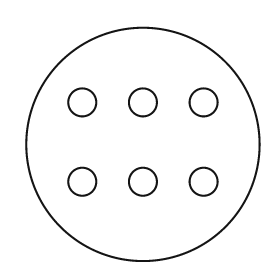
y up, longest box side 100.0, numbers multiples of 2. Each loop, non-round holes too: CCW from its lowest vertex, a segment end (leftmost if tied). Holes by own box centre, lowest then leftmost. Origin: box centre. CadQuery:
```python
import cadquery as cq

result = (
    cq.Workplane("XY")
    .moveTo(0.0, 0.0)
    .circle(50.0)
    .moveTo(-26.0, -16.0)
    .circle(6.0)
    .moveTo(0.0, -16.0)
    .circle(6.0)
    .moveTo(26.0, -16.0)
    .circle(6.0)
    .moveTo(-26.0, 18.0)
    .circle(6.0)
    .moveTo(0.0, 18.0)
    .circle(6.0)
    .moveTo(26.0, 18.0)
    .circle(6.0)
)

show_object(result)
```